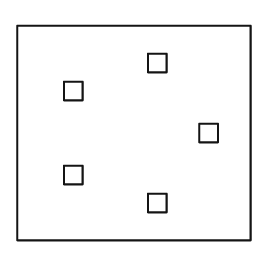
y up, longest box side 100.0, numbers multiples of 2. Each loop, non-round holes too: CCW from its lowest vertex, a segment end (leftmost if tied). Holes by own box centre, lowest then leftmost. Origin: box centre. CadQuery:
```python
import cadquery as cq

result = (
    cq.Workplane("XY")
    .moveTo(-50.0, -46.0)
    .lineTo(50.0, -46.0)
    .lineTo(50.0, 46.0)
    .lineTo(-50.0, 46.0)
    .close()
    .moveTo(6.0, -34.0)
    .lineTo(14.0, -34.0)
    .lineTo(14.0, -26.0)
    .lineTo(6.0, -26.0)
    .close()
    .moveTo(-30.0, -22.0)
    .lineTo(-22.0, -22.0)
    .lineTo(-22.0, -14.0)
    .lineTo(-30.0, -14.0)
    .close()
    .moveTo(28.0, -4.0)
    .lineTo(36.0, -4.0)
    .lineTo(36.0, 4.0)
    .lineTo(28.0, 4.0)
    .close()
    .moveTo(-30.0, 14.0)
    .lineTo(-22.0, 14.0)
    .lineTo(-22.0, 22.0)
    .lineTo(-30.0, 22.0)
    .close()
    .moveTo(6.0, 26.0)
    .lineTo(14.0, 26.0)
    .lineTo(14.0, 34.0)
    .lineTo(6.0, 34.0)
    .close()
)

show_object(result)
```